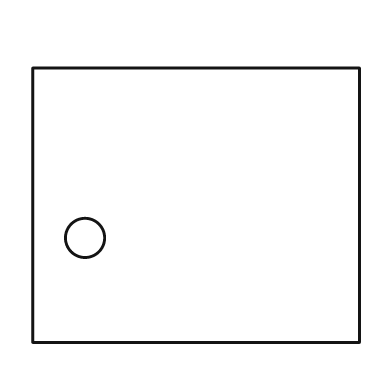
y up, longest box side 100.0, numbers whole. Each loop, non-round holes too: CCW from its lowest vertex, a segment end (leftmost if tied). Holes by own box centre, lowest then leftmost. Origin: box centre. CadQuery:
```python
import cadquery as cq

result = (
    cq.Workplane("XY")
    .moveTo(-50.0, -42.0)
    .lineTo(50.0, -42.0)
    .lineTo(50.0, 42.0)
    .lineTo(-50.0, 42.0)
    .close()
    .moveTo(-34.0, -10.0)
    .circle(6.0)
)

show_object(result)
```